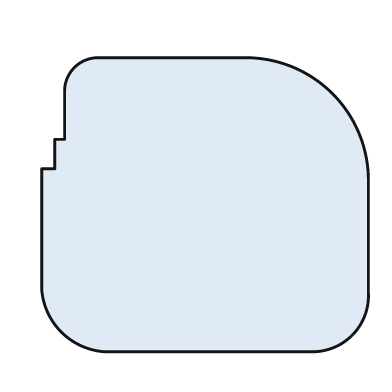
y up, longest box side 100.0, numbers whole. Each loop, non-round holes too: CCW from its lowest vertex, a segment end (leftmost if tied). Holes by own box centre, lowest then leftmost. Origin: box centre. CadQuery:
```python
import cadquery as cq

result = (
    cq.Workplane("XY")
    .moveTo(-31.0, -45.0)
    .lineTo(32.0, -45.0)
    .threePointArc((45.0, -40.0), (50.0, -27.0))
    .lineTo(50.0, 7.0)
    .threePointArc((39.0, 34.0), (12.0, 45.0))
    .lineTo(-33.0, 45.0)
    .threePointArc((-40.0, 42.0), (-43.0, 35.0))
    .lineTo(-43.0, 20.0)
    .lineTo(-46.0, 20.0)
    .lineTo(-46.0, 11.0)
    .lineTo(-50.0, 11.0)
    .lineTo(-50.0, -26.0)
    .threePointArc((-44.0, -39.0), (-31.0, -45.0))
    .close()
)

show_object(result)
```